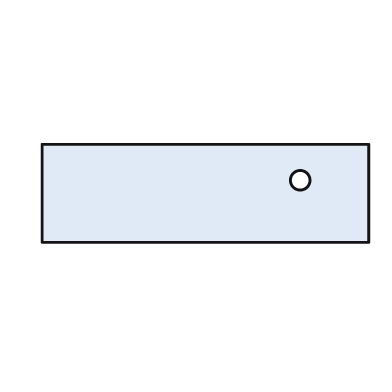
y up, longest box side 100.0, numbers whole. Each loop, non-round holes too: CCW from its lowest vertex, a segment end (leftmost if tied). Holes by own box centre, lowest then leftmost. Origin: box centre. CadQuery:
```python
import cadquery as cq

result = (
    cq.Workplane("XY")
    .moveTo(-50.0, -15.0)
    .lineTo(50.0, -15.0)
    .lineTo(50.0, 15.0)
    .lineTo(-50.0, 15.0)
    .close()
    .moveTo(29.0, 4.0)
    .circle(3.0)
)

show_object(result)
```